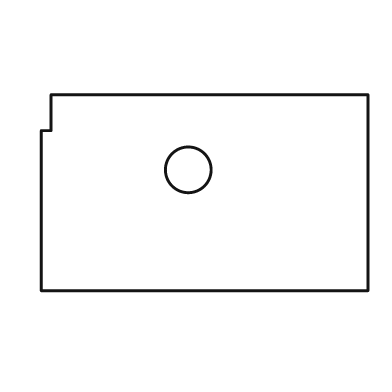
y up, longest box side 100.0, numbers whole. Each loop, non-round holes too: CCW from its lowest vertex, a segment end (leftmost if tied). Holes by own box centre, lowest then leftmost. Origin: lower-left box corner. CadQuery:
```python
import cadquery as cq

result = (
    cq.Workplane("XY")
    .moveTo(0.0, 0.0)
    .lineTo(100.0, 0.0)
    .lineTo(100.0, 60.0)
    .lineTo(3.0, 60.0)
    .lineTo(3.0, 49.0)
    .lineTo(0.0, 49.0)
    .close()
    .moveTo(45.0, 37.0)
    .circle(7.0)
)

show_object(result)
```